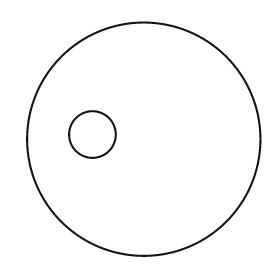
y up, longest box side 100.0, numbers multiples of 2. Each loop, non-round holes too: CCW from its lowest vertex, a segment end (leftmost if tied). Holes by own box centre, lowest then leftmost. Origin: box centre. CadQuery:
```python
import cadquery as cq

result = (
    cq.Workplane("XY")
    .moveTo(0.0, 0.0)
    .circle(50.0)
    .moveTo(-22.0, 2.0)
    .circle(10.0)
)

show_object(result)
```